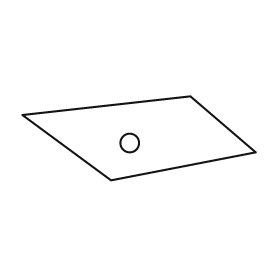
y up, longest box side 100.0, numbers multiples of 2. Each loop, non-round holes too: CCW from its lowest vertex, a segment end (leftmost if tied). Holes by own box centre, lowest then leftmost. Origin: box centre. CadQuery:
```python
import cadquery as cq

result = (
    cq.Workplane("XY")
    .moveTo(-12.0, -18.0)
    .lineTo(50.0, -6.0)
    .lineTo(22.0, 18.0)
    .lineTo(-50.0, 10.0)
    .close()
    .moveTo(-4.0, -2.0)
    .circle(4.0)
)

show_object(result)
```